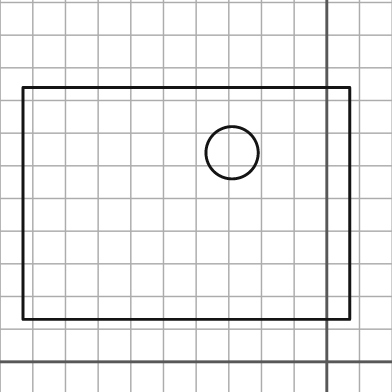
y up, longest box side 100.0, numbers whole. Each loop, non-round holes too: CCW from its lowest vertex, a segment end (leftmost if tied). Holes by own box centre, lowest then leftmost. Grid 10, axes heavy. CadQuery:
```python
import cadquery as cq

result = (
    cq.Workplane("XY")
    .moveTo(-93.0, 13.0)
    .lineTo(7.0, 13.0)
    .lineTo(7.0, 84.0)
    .lineTo(-93.0, 84.0)
    .close()
    .moveTo(-29.0, 64.0)
    .circle(8.0)
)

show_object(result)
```